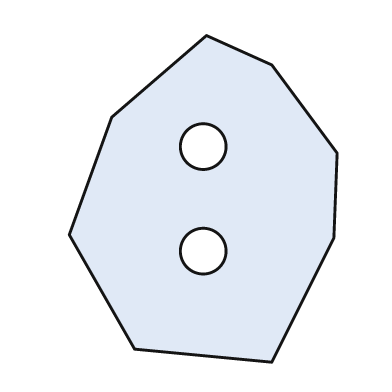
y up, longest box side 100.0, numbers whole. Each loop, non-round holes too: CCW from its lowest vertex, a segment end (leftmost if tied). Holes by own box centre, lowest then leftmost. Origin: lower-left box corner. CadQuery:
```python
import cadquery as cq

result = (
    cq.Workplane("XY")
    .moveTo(62.0, 0.0)
    .lineTo(81.0, 38.0)
    .lineTo(82.0, 64.0)
    .lineTo(62.0, 91.0)
    .lineTo(42.0, 100.0)
    .lineTo(13.0, 75.0)
    .lineTo(0.0, 39.0)
    .lineTo(20.0, 4.0)
    .close()
    .moveTo(41.0, 34.0)
    .circle(7.0)
    .moveTo(41.0, 66.0)
    .circle(7.0)
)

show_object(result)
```